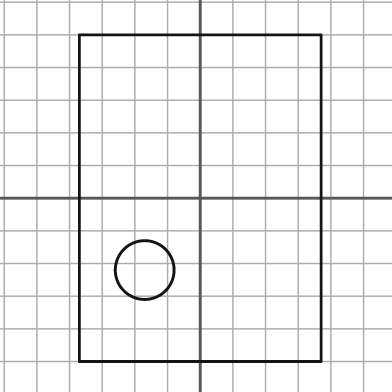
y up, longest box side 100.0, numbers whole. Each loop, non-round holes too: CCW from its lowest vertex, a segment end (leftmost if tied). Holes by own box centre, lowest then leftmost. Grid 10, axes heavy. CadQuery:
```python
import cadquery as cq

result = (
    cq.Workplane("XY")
    .moveTo(-37.0, -50.0)
    .lineTo(37.0, -50.0)
    .lineTo(37.0, 50.0)
    .lineTo(-37.0, 50.0)
    .close()
    .moveTo(-17.0, -22.0)
    .circle(9.0)
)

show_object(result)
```